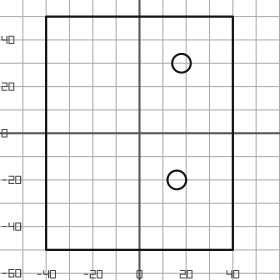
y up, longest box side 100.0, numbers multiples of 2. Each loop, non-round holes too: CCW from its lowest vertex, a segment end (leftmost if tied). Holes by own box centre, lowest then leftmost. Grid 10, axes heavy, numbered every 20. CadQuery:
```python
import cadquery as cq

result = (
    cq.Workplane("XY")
    .moveTo(-40.0, -50.0)
    .lineTo(40.0, -50.0)
    .lineTo(40.0, 50.0)
    .lineTo(-40.0, 50.0)
    .close()
    .moveTo(16.0, -20.0)
    .circle(4.0)
    .moveTo(18.0, 30.0)
    .circle(4.0)
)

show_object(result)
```